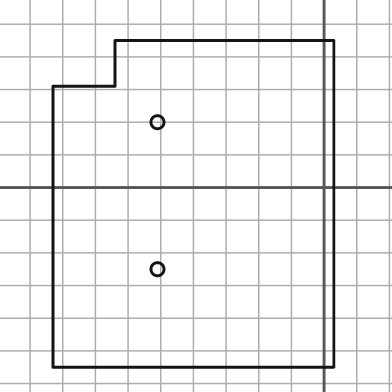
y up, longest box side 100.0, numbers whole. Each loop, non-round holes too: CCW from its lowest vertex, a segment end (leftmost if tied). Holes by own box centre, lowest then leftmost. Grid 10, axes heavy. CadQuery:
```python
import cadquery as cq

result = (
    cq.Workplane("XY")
    .moveTo(-83.0, -55.0)
    .lineTo(3.0, -55.0)
    .lineTo(3.0, 45.0)
    .lineTo(-64.0, 45.0)
    .lineTo(-64.0, 31.0)
    .lineTo(-83.0, 31.0)
    .close()
    .moveTo(-51.0, -25.0)
    .circle(2.0)
    .moveTo(-51.0, 20.0)
    .circle(2.0)
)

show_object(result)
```